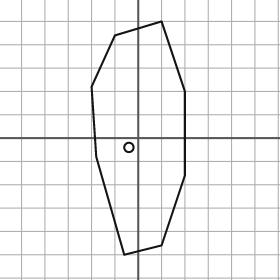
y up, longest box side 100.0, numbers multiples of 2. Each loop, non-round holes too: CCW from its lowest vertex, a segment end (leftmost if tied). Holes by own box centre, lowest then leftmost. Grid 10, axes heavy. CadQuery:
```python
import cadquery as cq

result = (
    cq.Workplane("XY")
    .moveTo(-6.0, -50.0)
    .lineTo(10.0, -46.0)
    .lineTo(20.0, -16.0)
    .lineTo(20.0, 20.0)
    .lineTo(10.0, 50.0)
    .lineTo(-10.0, 44.0)
    .lineTo(-20.0, 22.0)
    .lineTo(-18.0, -8.0)
    .close()
    .moveTo(-4.0, -4.0)
    .circle(2.0)
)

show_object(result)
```